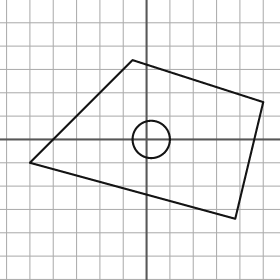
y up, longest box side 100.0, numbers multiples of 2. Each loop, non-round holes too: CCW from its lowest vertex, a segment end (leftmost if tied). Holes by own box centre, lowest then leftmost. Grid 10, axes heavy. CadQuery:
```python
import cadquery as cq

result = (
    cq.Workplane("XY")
    .moveTo(38.0, -34.0)
    .lineTo(50.0, 16.0)
    .lineTo(-6.0, 34.0)
    .lineTo(-50.0, -10.0)
    .close()
    .moveTo(2.0, 0.0)
    .circle(8.0)
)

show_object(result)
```